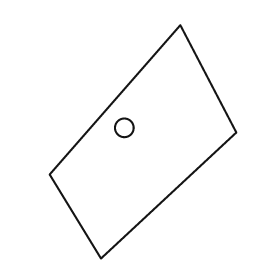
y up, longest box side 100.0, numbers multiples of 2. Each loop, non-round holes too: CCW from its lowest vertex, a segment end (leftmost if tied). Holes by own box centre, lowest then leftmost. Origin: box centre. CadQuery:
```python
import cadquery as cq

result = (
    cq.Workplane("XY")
    .moveTo(-18.0, -50.0)
    .lineTo(40.0, 4.0)
    .lineTo(16.0, 50.0)
    .lineTo(-40.0, -14.0)
    .close()
    .moveTo(-8.0, 6.0)
    .circle(4.0)
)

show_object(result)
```